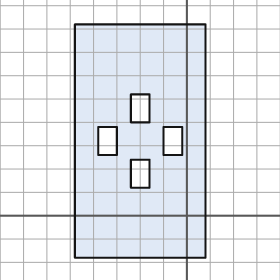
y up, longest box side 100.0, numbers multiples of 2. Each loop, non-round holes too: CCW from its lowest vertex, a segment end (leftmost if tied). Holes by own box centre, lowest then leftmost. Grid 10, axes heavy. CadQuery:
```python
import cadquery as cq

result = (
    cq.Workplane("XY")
    .moveTo(-48.0, -18.0)
    .lineTo(8.0, -18.0)
    .lineTo(8.0, 82.0)
    .lineTo(-48.0, 82.0)
    .close()
    .moveTo(-24.0, 12.0)
    .lineTo(-16.0, 12.0)
    .lineTo(-16.0, 24.0)
    .lineTo(-24.0, 24.0)
    .close()
    .moveTo(-38.0, 26.0)
    .lineTo(-30.0, 26.0)
    .lineTo(-30.0, 38.0)
    .lineTo(-38.0, 38.0)
    .close()
    .moveTo(-10.0, 26.0)
    .lineTo(-2.0, 26.0)
    .lineTo(-2.0, 38.0)
    .lineTo(-10.0, 38.0)
    .close()
    .moveTo(-24.0, 40.0)
    .lineTo(-16.0, 40.0)
    .lineTo(-16.0, 52.0)
    .lineTo(-24.0, 52.0)
    .close()
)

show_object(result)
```